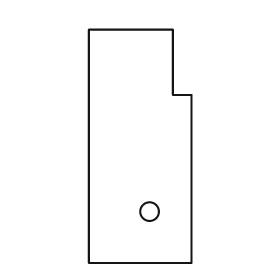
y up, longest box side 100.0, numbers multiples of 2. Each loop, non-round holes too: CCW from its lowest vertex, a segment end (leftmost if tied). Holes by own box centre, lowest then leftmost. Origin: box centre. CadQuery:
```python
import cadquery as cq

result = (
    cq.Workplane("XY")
    .moveTo(-22.0, -50.0)
    .lineTo(22.0, -50.0)
    .lineTo(22.0, 22.0)
    .lineTo(14.0, 22.0)
    .lineTo(14.0, 50.0)
    .lineTo(-22.0, 50.0)
    .close()
    .moveTo(4.0, -28.0)
    .circle(4.0)
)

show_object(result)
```